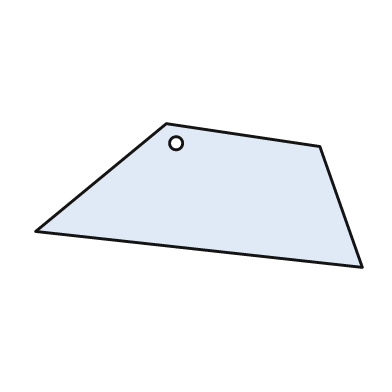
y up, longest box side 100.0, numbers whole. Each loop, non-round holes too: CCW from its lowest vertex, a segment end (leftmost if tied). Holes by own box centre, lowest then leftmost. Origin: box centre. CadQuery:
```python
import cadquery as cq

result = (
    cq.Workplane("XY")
    .moveTo(50.0, -22.0)
    .lineTo(37.0, 15.0)
    .lineTo(-10.0, 22.0)
    .lineTo(-50.0, -11.0)
    .close()
    .moveTo(-7.0, 16.0)
    .circle(2.0)
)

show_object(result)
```